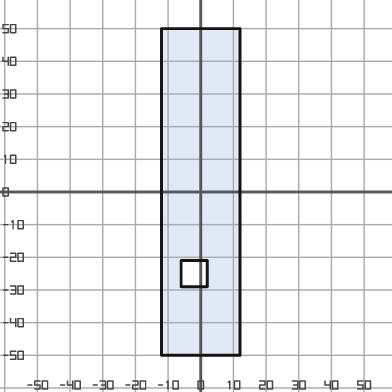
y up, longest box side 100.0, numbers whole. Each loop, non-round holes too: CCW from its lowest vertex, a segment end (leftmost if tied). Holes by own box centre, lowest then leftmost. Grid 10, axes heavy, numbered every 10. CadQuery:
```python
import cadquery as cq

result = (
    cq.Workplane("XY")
    .moveTo(-12.0, -50.0)
    .lineTo(12.0, -50.0)
    .lineTo(12.0, 50.0)
    .lineTo(-12.0, 50.0)
    .close()
    .moveTo(-6.0, -29.0)
    .lineTo(2.0, -29.0)
    .lineTo(2.0, -21.0)
    .lineTo(-6.0, -21.0)
    .close()
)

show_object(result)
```